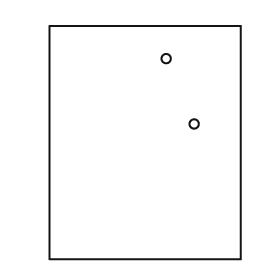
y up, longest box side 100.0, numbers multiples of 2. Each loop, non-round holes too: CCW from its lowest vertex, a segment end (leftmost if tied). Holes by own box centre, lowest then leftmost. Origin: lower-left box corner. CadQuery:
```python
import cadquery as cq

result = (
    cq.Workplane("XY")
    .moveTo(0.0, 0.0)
    .lineTo(82.0, 0.0)
    .lineTo(82.0, 100.0)
    .lineTo(0.0, 100.0)
    .close()
    .moveTo(62.0, 58.0)
    .circle(2.0)
    .moveTo(50.0, 86.0)
    .circle(2.0)
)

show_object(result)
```